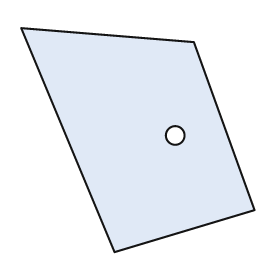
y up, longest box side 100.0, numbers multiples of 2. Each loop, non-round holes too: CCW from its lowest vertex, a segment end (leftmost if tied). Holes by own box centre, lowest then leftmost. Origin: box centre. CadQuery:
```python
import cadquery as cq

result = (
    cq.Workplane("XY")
    .moveTo(-10.0, -48.0)
    .lineTo(50.0, -30.0)
    .lineTo(24.0, 42.0)
    .lineTo(-50.0, 48.0)
    .close()
    .moveTo(16.0, 2.0)
    .circle(4.0)
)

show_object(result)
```